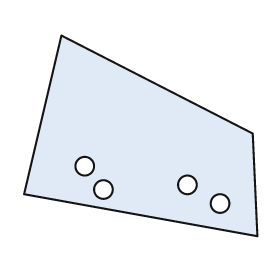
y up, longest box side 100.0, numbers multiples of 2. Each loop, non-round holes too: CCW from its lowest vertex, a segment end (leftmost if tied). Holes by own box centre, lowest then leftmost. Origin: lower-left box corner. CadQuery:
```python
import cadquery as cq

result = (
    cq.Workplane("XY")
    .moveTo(100.0, 0.0)
    .lineTo(98.0, 44.0)
    .lineTo(16.0, 86.0)
    .lineTo(0.0, 18.0)
    .close()
    .moveTo(84.0, 14.0)
    .circle(4.0)
    .moveTo(34.0, 20.0)
    .circle(4.0)
    .moveTo(70.0, 22.0)
    .circle(4.0)
    .moveTo(26.0, 30.0)
    .circle(4.0)
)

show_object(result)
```